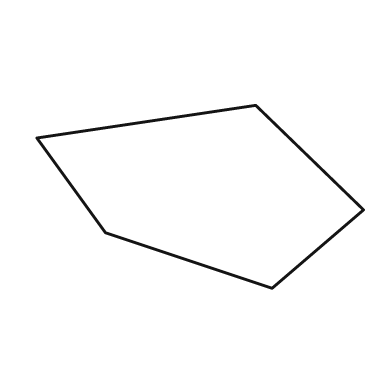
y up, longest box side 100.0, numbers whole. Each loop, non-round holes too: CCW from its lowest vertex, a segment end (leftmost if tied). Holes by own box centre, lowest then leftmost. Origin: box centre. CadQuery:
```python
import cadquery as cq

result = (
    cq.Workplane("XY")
    .moveTo(22.0, -28.0)
    .lineTo(50.0, -4.0)
    .lineTo(17.0, 28.0)
    .lineTo(-50.0, 18.0)
    .lineTo(-29.0, -11.0)
    .close()
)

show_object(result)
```